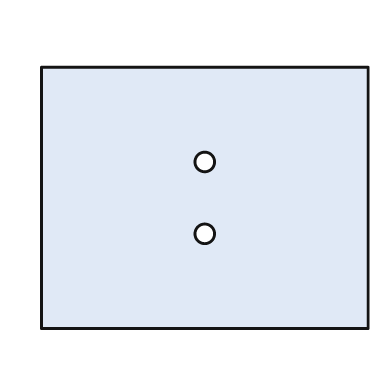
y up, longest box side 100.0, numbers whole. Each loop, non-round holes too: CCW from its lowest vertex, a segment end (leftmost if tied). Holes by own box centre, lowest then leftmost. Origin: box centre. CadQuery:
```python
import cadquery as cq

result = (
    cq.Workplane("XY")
    .moveTo(-50.0, -40.0)
    .lineTo(50.0, -40.0)
    .lineTo(50.0, 40.0)
    .lineTo(-50.0, 40.0)
    .close()
    .moveTo(0.0, -11.0)
    .circle(3.0)
    .moveTo(0.0, 11.0)
    .circle(3.0)
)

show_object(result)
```